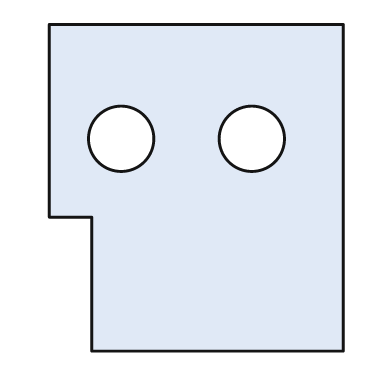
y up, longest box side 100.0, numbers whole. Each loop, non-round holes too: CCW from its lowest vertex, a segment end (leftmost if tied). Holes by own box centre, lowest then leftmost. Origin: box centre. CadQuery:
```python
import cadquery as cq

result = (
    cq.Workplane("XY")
    .moveTo(-32.0, -50.0)
    .lineTo(45.0, -50.0)
    .lineTo(45.0, 50.0)
    .lineTo(-45.0, 50.0)
    .lineTo(-45.0, -9.0)
    .lineTo(-32.0, -9.0)
    .close()
    .moveTo(-23.0, 15.0)
    .circle(10.0)
    .moveTo(17.0, 15.0)
    .circle(10.0)
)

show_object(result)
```